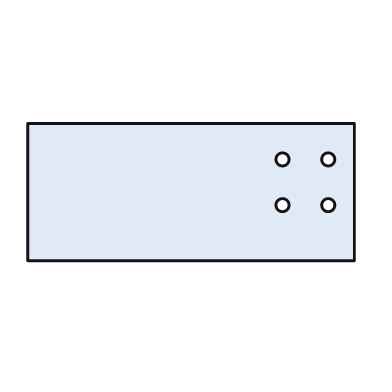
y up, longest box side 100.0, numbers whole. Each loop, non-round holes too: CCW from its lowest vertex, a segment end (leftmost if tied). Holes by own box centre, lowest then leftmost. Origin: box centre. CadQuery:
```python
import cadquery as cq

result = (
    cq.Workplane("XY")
    .moveTo(-50.0, -21.0)
    .lineTo(50.0, -21.0)
    .lineTo(50.0, 21.0)
    .lineTo(-50.0, 21.0)
    .close()
    .moveTo(28.0, -4.0)
    .circle(2.0)
    .moveTo(42.0, -4.0)
    .circle(2.0)
    .moveTo(28.0, 10.0)
    .circle(2.0)
    .moveTo(42.0, 10.0)
    .circle(2.0)
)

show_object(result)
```